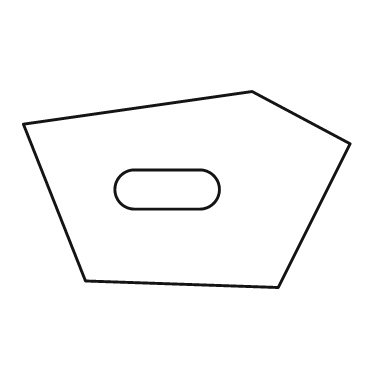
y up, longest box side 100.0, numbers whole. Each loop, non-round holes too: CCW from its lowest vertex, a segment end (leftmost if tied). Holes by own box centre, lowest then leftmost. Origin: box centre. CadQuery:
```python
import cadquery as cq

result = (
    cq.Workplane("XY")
    .moveTo(28.0, -30.0)
    .lineTo(50.0, 14.0)
    .lineTo(20.0, 30.0)
    .lineTo(-50.0, 20.0)
    .lineTo(-31.0, -28.0)
    .close()
    .moveTo(-16.0, -6.0)
    .lineTo(4.0, -6.0)
    .threePointArc((10.0, 0.0), (4.0, 6.0))
    .lineTo(-16.0, 6.0)
    .threePointArc((-22.0, 0.0), (-16.0, -6.0))
    .close()
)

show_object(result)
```